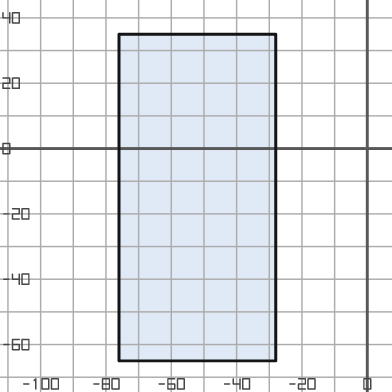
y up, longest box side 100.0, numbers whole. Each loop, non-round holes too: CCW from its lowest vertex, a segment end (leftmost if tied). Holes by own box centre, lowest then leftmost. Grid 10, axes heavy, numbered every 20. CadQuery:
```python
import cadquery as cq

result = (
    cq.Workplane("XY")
    .moveTo(-76.0, -65.0)
    .lineTo(-28.0, -65.0)
    .lineTo(-28.0, 35.0)
    .lineTo(-76.0, 35.0)
    .close()
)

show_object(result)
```